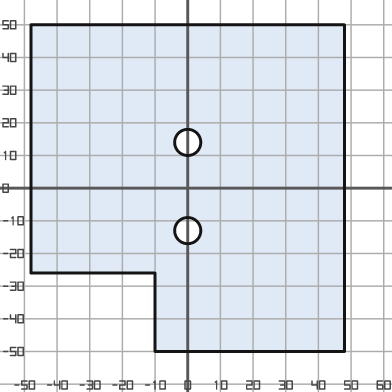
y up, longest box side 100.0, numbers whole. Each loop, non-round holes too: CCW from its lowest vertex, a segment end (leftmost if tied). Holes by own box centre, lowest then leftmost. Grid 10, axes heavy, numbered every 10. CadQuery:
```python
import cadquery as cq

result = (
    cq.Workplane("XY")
    .moveTo(-10.0, -50.0)
    .lineTo(48.0, -50.0)
    .lineTo(48.0, 50.0)
    .lineTo(-48.0, 50.0)
    .lineTo(-48.0, -26.0)
    .lineTo(-10.0, -26.0)
    .close()
    .moveTo(0.0, -13.0)
    .circle(4.0)
    .moveTo(0.0, 14.0)
    .circle(4.0)
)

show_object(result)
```